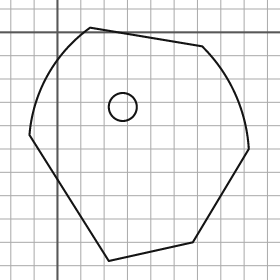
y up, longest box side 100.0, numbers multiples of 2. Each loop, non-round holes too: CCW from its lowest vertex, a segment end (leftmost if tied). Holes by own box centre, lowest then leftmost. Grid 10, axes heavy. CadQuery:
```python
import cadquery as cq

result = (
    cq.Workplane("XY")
    .moveTo(22.0, -98.0)
    .lineTo(58.0, -90.0)
    .lineTo(82.0, -50.0)
    .threePointArc((76.0, -26.0), (62.0, -6.0))
    .lineTo(14.0, 2.0)
    .threePointArc((-4.0, -18.0), (-12.0, -44.0))
    .close()
    .moveTo(28.0, -32.0)
    .circle(6.0)
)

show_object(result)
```